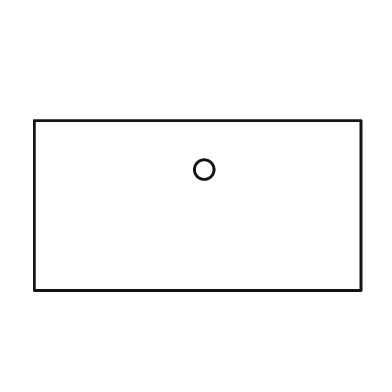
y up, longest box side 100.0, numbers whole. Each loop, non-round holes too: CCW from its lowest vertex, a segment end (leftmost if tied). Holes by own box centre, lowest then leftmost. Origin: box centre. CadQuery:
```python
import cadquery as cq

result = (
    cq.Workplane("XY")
    .moveTo(-50.0, -26.0)
    .lineTo(50.0, -26.0)
    .lineTo(50.0, 26.0)
    .lineTo(-50.0, 26.0)
    .close()
    .moveTo(2.0, 11.0)
    .circle(3.0)
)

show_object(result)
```